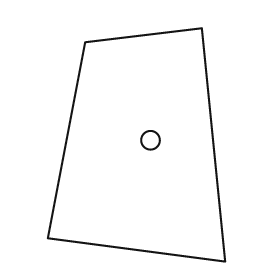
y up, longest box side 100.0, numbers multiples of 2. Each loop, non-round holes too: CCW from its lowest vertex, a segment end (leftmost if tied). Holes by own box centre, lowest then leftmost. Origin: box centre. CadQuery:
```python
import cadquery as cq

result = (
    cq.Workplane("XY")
    .moveTo(38.0, -50.0)
    .lineTo(28.0, 50.0)
    .lineTo(-22.0, 44.0)
    .lineTo(-38.0, -40.0)
    .close()
    .moveTo(6.0, 2.0)
    .circle(4.0)
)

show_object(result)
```